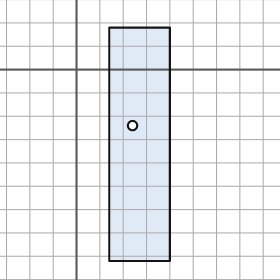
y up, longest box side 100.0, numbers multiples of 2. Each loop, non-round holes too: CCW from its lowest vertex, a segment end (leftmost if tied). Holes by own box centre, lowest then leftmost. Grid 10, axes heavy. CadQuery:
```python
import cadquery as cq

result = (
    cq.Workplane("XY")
    .moveTo(14.0, -82.0)
    .lineTo(40.0, -82.0)
    .lineTo(40.0, 18.0)
    .lineTo(14.0, 18.0)
    .close()
    .moveTo(24.0, -24.0)
    .circle(2.0)
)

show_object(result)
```